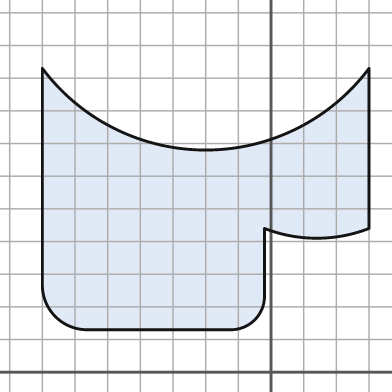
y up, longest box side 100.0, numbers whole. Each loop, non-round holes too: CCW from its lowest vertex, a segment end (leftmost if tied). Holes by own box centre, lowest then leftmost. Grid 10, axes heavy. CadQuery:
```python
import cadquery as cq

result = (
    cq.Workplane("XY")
    .moveTo(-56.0, 13.0)
    .lineTo(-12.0, 13.0)
    .threePointArc((-5.0, 16.0), (-2.0, 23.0))
    .lineTo(-2.0, 44.0)
    .threePointArc((14.0, 41.0), (30.0, 44.0))
    .lineTo(30.0, 93.0)
    .threePointArc((-20.0, 68.0), (-70.0, 93.0))
    .lineTo(-70.0, 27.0)
    .threePointArc((-66.0, 17.0), (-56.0, 13.0))
    .close()
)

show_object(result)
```